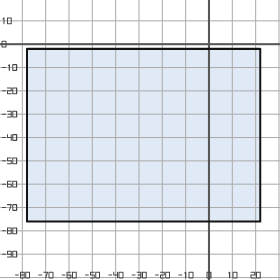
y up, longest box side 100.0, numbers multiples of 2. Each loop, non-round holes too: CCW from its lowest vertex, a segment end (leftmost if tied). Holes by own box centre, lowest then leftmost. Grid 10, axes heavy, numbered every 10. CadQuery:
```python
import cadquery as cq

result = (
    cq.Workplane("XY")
    .moveTo(-78.0, -76.0)
    .lineTo(22.0, -76.0)
    .lineTo(22.0, -2.0)
    .lineTo(-78.0, -2.0)
    .close()
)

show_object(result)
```